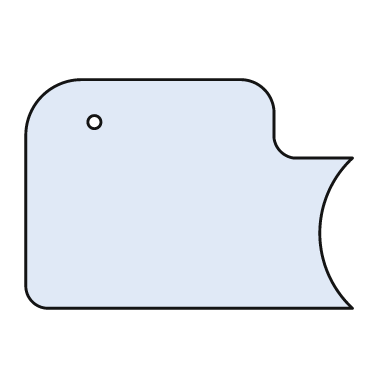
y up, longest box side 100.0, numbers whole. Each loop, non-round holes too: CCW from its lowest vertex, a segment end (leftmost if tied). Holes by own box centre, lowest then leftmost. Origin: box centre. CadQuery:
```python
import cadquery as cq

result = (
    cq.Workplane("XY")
    .moveTo(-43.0, -35.0)
    .lineTo(50.0, -35.0)
    .threePointArc((40.0, -12.0), (50.0, 11.0))
    .lineTo(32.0, 11.0)
    .threePointArc((28.0, 13.0), (26.0, 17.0))
    .lineTo(26.0, 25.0)
    .threePointArc((23.0, 32.0), (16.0, 35.0))
    .lineTo(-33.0, 35.0)
    .threePointArc((-45.0, 30.0), (-50.0, 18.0))
    .lineTo(-50.0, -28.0)
    .threePointArc((-48.0, -33.0), (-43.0, -35.0))
    .close()
    .moveTo(-29.0, 22.0)
    .circle(2.0)
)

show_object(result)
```